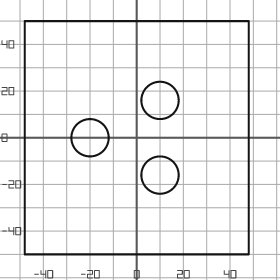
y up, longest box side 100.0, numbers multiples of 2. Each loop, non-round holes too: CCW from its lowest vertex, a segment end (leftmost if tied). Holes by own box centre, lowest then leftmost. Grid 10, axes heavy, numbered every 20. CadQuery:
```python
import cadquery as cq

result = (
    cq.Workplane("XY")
    .moveTo(-48.0, -50.0)
    .lineTo(48.0, -50.0)
    .lineTo(48.0, 50.0)
    .lineTo(-48.0, 50.0)
    .close()
    .moveTo(10.0, -16.0)
    .circle(8.0)
    .moveTo(-20.0, 0.0)
    .circle(8.0)
    .moveTo(10.0, 16.0)
    .circle(8.0)
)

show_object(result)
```